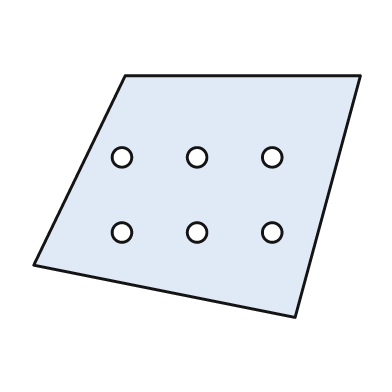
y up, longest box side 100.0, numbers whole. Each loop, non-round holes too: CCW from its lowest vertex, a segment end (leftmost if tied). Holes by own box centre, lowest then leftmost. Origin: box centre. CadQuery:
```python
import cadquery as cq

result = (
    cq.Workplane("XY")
    .moveTo(30.0, -37.0)
    .lineTo(50.0, 37.0)
    .lineTo(-22.0, 37.0)
    .lineTo(-50.0, -21.0)
    .close()
    .moveTo(-23.0, -11.0)
    .circle(3.0)
    .moveTo(0.0, -11.0)
    .circle(3.0)
    .moveTo(23.0, -11.0)
    .circle(3.0)
    .moveTo(-23.0, 12.0)
    .circle(3.0)
    .moveTo(0.0, 12.0)
    .circle(3.0)
    .moveTo(23.0, 12.0)
    .circle(3.0)
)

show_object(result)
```